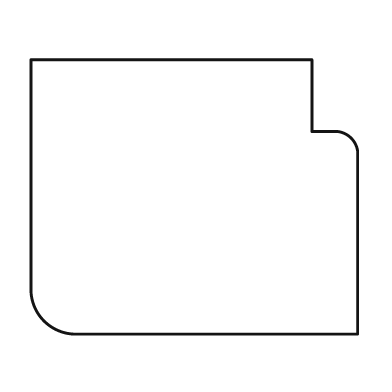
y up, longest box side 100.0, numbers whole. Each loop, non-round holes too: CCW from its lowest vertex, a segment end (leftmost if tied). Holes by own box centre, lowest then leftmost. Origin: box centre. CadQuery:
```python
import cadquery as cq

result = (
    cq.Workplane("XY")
    .moveTo(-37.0, -42.0)
    .lineTo(50.0, -42.0)
    .lineTo(50.0, 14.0)
    .threePointArc((48.0, 18.0), (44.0, 20.0))
    .lineTo(36.0, 20.0)
    .lineTo(36.0, 42.0)
    .lineTo(-50.0, 42.0)
    .lineTo(-50.0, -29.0)
    .threePointArc((-46.0, -38.0), (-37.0, -42.0))
    .close()
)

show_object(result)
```